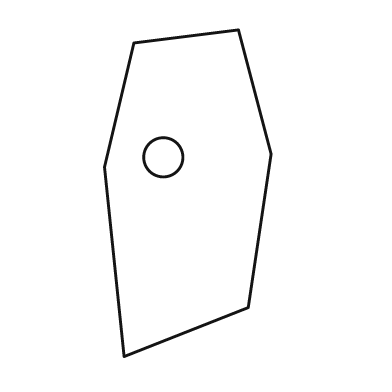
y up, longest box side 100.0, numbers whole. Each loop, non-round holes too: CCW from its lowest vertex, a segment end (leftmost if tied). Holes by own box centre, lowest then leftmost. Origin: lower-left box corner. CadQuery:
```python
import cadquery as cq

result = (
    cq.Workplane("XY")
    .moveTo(6.0, 0.0)
    .lineTo(44.0, 15.0)
    .lineTo(51.0, 62.0)
    .lineTo(41.0, 100.0)
    .lineTo(9.0, 96.0)
    .lineTo(0.0, 58.0)
    .close()
    .moveTo(18.0, 61.0)
    .circle(6.0)
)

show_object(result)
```